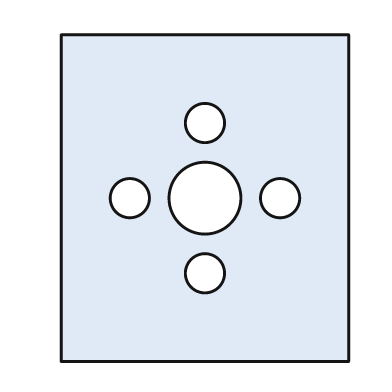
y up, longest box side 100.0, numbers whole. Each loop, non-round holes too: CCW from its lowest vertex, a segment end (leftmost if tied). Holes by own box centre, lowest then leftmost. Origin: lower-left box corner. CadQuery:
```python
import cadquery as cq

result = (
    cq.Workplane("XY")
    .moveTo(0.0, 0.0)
    .lineTo(88.0, 0.0)
    .lineTo(88.0, 100.0)
    .lineTo(0.0, 100.0)
    .close()
    .moveTo(44.0, 27.0)
    .circle(6.0)
    .moveTo(21.0, 50.0)
    .circle(6.0)
    .moveTo(44.0, 50.0)
    .circle(11.0)
    .moveTo(67.0, 50.0)
    .circle(6.0)
    .moveTo(44.0, 73.0)
    .circle(6.0)
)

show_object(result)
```